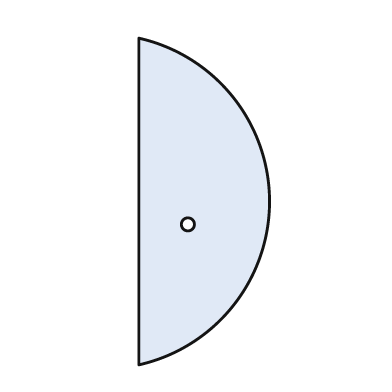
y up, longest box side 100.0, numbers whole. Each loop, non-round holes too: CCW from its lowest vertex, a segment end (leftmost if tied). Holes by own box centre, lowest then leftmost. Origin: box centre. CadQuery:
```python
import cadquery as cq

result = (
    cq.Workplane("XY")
    .moveTo(-20.0, -50.0)
    .threePointArc((20.0, 0.0), (-20.0, 50.0))
    .close()
    .moveTo(-5.0, -7.0)
    .circle(2.0)
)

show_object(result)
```